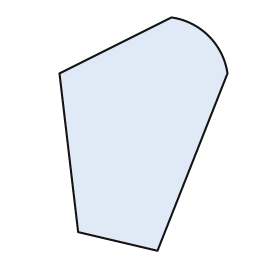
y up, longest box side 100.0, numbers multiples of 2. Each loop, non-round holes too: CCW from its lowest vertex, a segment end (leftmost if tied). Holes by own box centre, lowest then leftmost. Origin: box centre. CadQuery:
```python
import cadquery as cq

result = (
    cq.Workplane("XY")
    .moveTo(6.0, -50.0)
    .lineTo(36.0, 26.0)
    .threePointArc((28.0, 42.0), (12.0, 50.0))
    .lineTo(-36.0, 26.0)
    .lineTo(-28.0, -42.0)
    .close()
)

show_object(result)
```